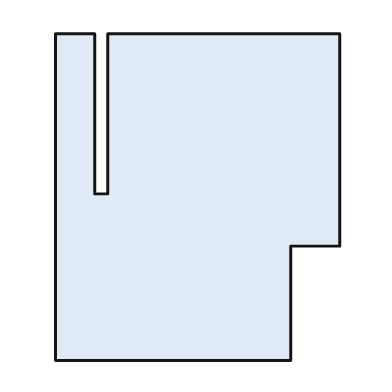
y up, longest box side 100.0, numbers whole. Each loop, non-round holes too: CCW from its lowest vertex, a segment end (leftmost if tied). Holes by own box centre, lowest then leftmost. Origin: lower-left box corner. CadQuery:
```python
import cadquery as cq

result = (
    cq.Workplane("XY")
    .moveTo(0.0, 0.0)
    .lineTo(72.0, 0.0)
    .lineTo(72.0, 35.0)
    .lineTo(87.0, 35.0)
    .lineTo(87.0, 100.0)
    .lineTo(16.0, 100.0)
    .lineTo(16.0, 51.0)
    .lineTo(12.0, 51.0)
    .lineTo(12.0, 100.0)
    .lineTo(0.0, 100.0)
    .close()
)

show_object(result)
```